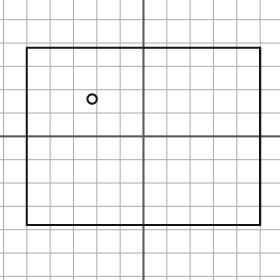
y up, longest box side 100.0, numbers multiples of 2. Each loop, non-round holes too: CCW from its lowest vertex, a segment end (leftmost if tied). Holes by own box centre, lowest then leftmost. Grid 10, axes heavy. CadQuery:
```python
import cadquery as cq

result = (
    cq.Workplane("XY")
    .moveTo(-50.0, -38.0)
    .lineTo(50.0, -38.0)
    .lineTo(50.0, 38.0)
    .lineTo(-50.0, 38.0)
    .close()
    .moveTo(-22.0, 16.0)
    .circle(2.0)
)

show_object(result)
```